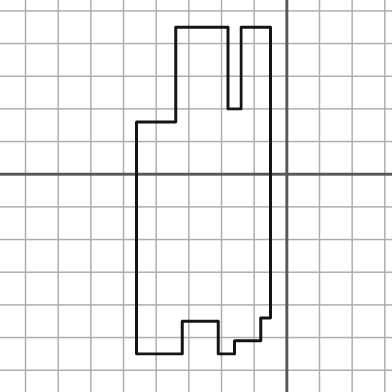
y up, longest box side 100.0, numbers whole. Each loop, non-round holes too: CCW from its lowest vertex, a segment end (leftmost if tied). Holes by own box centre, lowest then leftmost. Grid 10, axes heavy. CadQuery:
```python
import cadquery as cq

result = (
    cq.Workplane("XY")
    .moveTo(-46.0, -55.0)
    .lineTo(-32.0, -55.0)
    .lineTo(-32.0, -45.0)
    .lineTo(-21.0, -45.0)
    .lineTo(-21.0, -55.0)
    .lineTo(-16.0, -55.0)
    .lineTo(-16.0, -51.0)
    .lineTo(-8.0, -51.0)
    .lineTo(-8.0, -44.0)
    .lineTo(-5.0, -44.0)
    .lineTo(-5.0, 45.0)
    .lineTo(-14.0, 45.0)
    .lineTo(-14.0, 20.0)
    .lineTo(-18.0, 20.0)
    .lineTo(-18.0, 45.0)
    .lineTo(-34.0, 45.0)
    .lineTo(-34.0, 16.0)
    .lineTo(-46.0, 16.0)
    .close()
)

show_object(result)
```